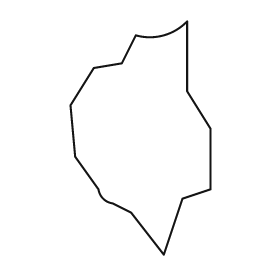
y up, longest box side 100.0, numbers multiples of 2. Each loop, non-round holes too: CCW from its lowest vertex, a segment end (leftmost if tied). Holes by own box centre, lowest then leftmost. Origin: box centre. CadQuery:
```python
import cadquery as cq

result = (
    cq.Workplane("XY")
    .moveTo(10.0, -50.0)
    .lineTo(18.0, -26.0)
    .lineTo(30.0, -22.0)
    .lineTo(30.0, 4.0)
    .lineTo(20.0, 20.0)
    .lineTo(20.0, 50.0)
    .threePointArc((10.0, 44.0), (-2.0, 44.0))
    .lineTo(-8.0, 32.0)
    .lineTo(-20.0, 30.0)
    .lineTo(-30.0, 14.0)
    .lineTo(-28.0, -8.0)
    .lineTo(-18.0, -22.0)
    .threePointArc((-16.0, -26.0), (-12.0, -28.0))
    .lineTo(-4.0, -32.0)
    .close()
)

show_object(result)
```